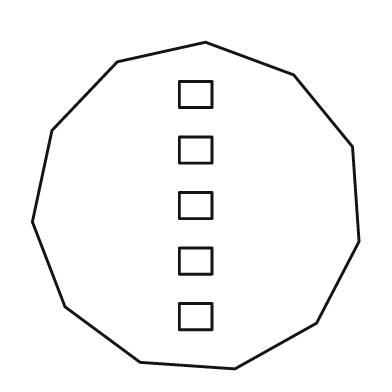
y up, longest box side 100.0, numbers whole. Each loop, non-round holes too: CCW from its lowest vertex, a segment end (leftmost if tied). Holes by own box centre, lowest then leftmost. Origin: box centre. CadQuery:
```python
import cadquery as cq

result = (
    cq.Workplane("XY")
    .moveTo(12.0, -50.0)
    .lineTo(37.0, -36.0)
    .lineTo(50.0, -11.0)
    .lineTo(48.0, 18.0)
    .lineTo(30.0, 40.0)
    .lineTo(3.0, 50.0)
    .lineTo(-24.0, 44.0)
    .lineTo(-44.0, 23.0)
    .lineTo(-50.0, -5.0)
    .lineTo(-40.0, -31.0)
    .lineTo(-17.0, -48.0)
    .close()
    .moveTo(-5.0, -38.0)
    .lineTo(5.0, -38.0)
    .lineTo(5.0, -30.0)
    .lineTo(-5.0, -30.0)
    .close()
    .moveTo(-5.0, -21.0)
    .lineTo(5.0, -21.0)
    .lineTo(5.0, -13.0)
    .lineTo(-5.0, -13.0)
    .close()
    .moveTo(-5.0, -4.0)
    .lineTo(5.0, -4.0)
    .lineTo(5.0, 4.0)
    .lineTo(-5.0, 4.0)
    .close()
    .moveTo(-5.0, 13.0)
    .lineTo(5.0, 13.0)
    .lineTo(5.0, 21.0)
    .lineTo(-5.0, 21.0)
    .close()
    .moveTo(-5.0, 30.0)
    .lineTo(5.0, 30.0)
    .lineTo(5.0, 38.0)
    .lineTo(-5.0, 38.0)
    .close()
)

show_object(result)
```